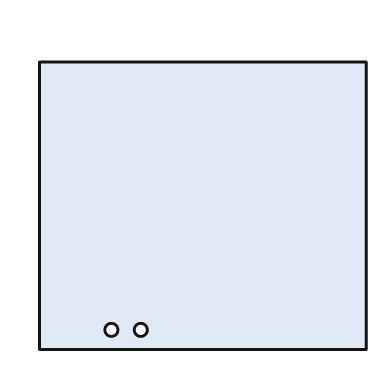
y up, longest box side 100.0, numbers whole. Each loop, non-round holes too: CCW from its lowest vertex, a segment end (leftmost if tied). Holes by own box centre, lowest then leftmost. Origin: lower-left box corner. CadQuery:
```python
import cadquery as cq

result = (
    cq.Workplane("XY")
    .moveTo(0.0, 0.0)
    .lineTo(100.0, 0.0)
    .lineTo(100.0, 88.0)
    .lineTo(0.0, 88.0)
    .close()
    .moveTo(22.0, 6.0)
    .circle(2.0)
    .moveTo(31.0, 6.0)
    .circle(2.0)
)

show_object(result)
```